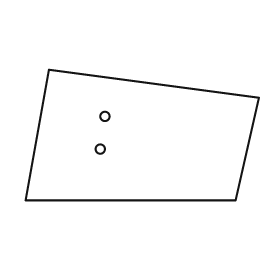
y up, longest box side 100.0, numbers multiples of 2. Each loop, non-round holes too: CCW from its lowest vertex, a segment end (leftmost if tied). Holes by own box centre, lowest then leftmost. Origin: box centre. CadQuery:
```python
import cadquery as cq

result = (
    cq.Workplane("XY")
    .moveTo(-50.0, -28.0)
    .lineTo(40.0, -28.0)
    .lineTo(50.0, 16.0)
    .lineTo(-40.0, 28.0)
    .close()
    .moveTo(-18.0, -6.0)
    .circle(2.0)
    .moveTo(-16.0, 8.0)
    .circle(2.0)
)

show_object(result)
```